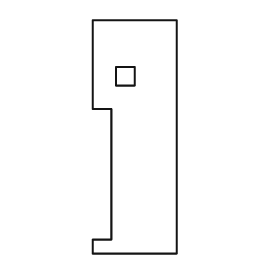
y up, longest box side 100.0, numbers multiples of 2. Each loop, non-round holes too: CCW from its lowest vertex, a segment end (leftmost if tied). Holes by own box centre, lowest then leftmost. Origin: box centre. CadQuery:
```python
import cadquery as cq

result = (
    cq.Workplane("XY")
    .moveTo(-18.0, -50.0)
    .lineTo(18.0, -50.0)
    .lineTo(18.0, 50.0)
    .lineTo(-18.0, 50.0)
    .lineTo(-18.0, 12.0)
    .lineTo(-10.0, 12.0)
    .lineTo(-10.0, -44.0)
    .lineTo(-18.0, -44.0)
    .close()
    .moveTo(-8.0, 22.0)
    .lineTo(0.0, 22.0)
    .lineTo(0.0, 30.0)
    .lineTo(-8.0, 30.0)
    .close()
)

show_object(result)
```